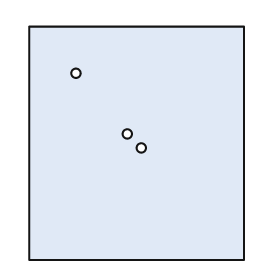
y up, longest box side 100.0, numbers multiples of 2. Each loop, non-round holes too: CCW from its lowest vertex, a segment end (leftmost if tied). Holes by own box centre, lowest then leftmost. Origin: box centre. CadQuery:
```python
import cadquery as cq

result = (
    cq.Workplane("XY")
    .moveTo(-46.0, -50.0)
    .lineTo(46.0, -50.0)
    .lineTo(46.0, 50.0)
    .lineTo(-46.0, 50.0)
    .close()
    .moveTo(2.0, -2.0)
    .circle(2.0)
    .moveTo(-4.0, 4.0)
    .circle(2.0)
    .moveTo(-26.0, 30.0)
    .circle(2.0)
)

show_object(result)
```